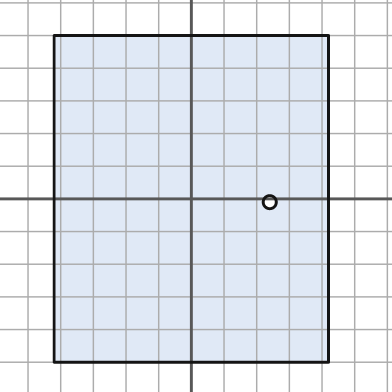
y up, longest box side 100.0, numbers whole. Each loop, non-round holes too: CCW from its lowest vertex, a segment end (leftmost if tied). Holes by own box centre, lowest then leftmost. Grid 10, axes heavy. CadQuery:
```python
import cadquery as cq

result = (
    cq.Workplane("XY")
    .moveTo(-42.0, -50.0)
    .lineTo(42.0, -50.0)
    .lineTo(42.0, 50.0)
    .lineTo(-42.0, 50.0)
    .close()
    .moveTo(24.0, -1.0)
    .circle(2.0)
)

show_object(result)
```